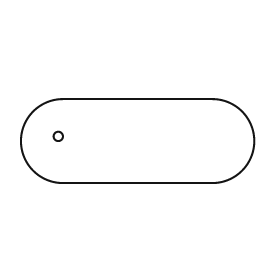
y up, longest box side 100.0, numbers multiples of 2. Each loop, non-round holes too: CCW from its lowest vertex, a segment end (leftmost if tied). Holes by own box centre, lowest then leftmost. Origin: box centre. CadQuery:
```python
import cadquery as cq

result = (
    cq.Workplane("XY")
    .moveTo(-32.0, -18.0)
    .lineTo(32.0, -18.0)
    .threePointArc((50.0, 0.0), (32.0, 18.0))
    .lineTo(-32.0, 18.0)
    .threePointArc((-50.0, 0.0), (-32.0, -18.0))
    .close()
    .moveTo(-34.0, 2.0)
    .circle(2.0)
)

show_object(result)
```